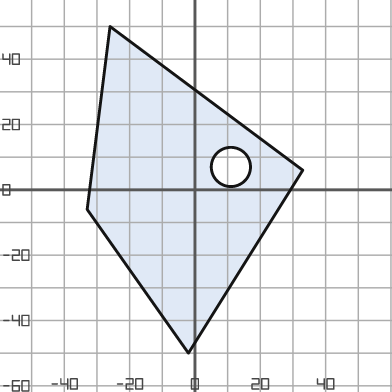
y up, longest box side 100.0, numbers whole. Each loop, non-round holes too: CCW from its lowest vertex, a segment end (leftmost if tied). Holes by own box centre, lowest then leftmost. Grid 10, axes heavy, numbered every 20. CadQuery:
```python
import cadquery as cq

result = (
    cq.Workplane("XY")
    .moveTo(-2.0, -50.0)
    .lineTo(33.0, 6.0)
    .lineTo(-26.0, 50.0)
    .lineTo(-33.0, -6.0)
    .close()
    .moveTo(11.0, 7.0)
    .circle(6.0)
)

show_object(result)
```